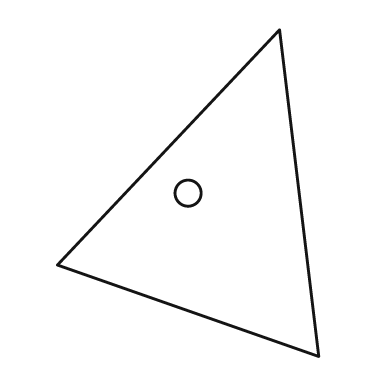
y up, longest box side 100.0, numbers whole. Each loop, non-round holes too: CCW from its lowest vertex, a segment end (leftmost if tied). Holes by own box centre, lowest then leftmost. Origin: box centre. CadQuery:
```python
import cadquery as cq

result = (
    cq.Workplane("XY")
    .moveTo(40.0, -50.0)
    .lineTo(28.0, 50.0)
    .lineTo(-40.0, -22.0)
    .close()
    .moveTo(0.0, 0.0)
    .circle(4.0)
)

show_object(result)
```